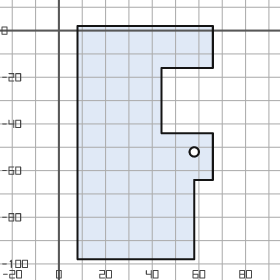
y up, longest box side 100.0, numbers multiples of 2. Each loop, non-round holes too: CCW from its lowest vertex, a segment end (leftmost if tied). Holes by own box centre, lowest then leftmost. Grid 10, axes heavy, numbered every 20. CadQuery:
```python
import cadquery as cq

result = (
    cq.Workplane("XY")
    .moveTo(8.0, -98.0)
    .lineTo(58.0, -98.0)
    .lineTo(58.0, -64.0)
    .lineTo(66.0, -64.0)
    .lineTo(66.0, -44.0)
    .lineTo(44.0, -44.0)
    .lineTo(44.0, -16.0)
    .lineTo(66.0, -16.0)
    .lineTo(66.0, 2.0)
    .lineTo(8.0, 2.0)
    .close()
    .moveTo(58.0, -52.0)
    .circle(2.0)
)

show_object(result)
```